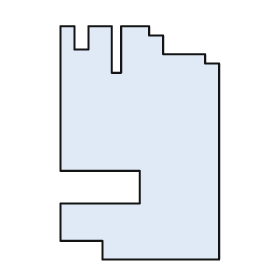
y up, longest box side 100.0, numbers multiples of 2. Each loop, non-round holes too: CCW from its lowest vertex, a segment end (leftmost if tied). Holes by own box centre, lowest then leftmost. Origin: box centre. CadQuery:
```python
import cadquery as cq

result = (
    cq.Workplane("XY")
    .moveTo(-16.0, -50.0)
    .lineTo(34.0, -50.0)
    .lineTo(34.0, 34.0)
    .lineTo(28.0, 34.0)
    .lineTo(28.0, 38.0)
    .lineTo(10.0, 38.0)
    .lineTo(10.0, 46.0)
    .lineTo(4.0, 46.0)
    .lineTo(4.0, 50.0)
    .lineTo(-8.0, 50.0)
    .lineTo(-8.0, 30.0)
    .lineTo(-12.0, 30.0)
    .lineTo(-12.0, 50.0)
    .lineTo(-22.0, 50.0)
    .lineTo(-22.0, 40.0)
    .lineTo(-28.0, 40.0)
    .lineTo(-28.0, 50.0)
    .lineTo(-34.0, 50.0)
    .lineTo(-34.0, -12.0)
    .lineTo(0.0, -12.0)
    .lineTo(0.0, -26.0)
    .lineTo(-34.0, -26.0)
    .lineTo(-34.0, -42.0)
    .lineTo(-16.0, -42.0)
    .close()
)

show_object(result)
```